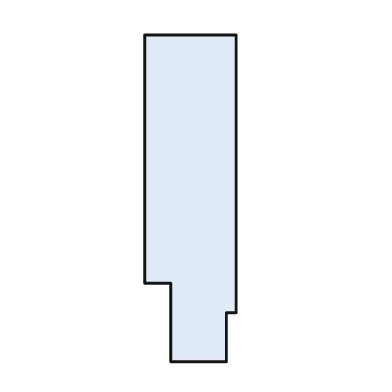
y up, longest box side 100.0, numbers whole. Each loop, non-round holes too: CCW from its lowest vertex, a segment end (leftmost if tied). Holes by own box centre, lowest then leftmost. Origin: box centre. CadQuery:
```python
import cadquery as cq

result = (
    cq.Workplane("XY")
    .moveTo(-6.0, -50.0)
    .lineTo(11.0, -50.0)
    .lineTo(11.0, -35.0)
    .lineTo(14.0, -35.0)
    .lineTo(14.0, 50.0)
    .lineTo(-14.0, 50.0)
    .lineTo(-14.0, -26.0)
    .lineTo(-6.0, -26.0)
    .close()
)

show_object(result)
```